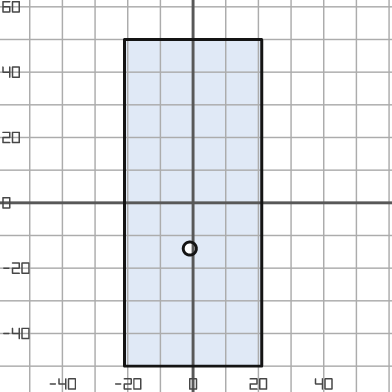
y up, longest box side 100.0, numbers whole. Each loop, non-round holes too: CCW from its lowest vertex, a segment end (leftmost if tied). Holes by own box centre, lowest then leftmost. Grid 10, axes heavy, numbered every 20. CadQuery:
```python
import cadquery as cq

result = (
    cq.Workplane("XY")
    .moveTo(-21.0, -50.0)
    .lineTo(21.0, -50.0)
    .lineTo(21.0, 50.0)
    .lineTo(-21.0, 50.0)
    .close()
    .moveTo(-1.0, -14.0)
    .circle(2.0)
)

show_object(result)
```